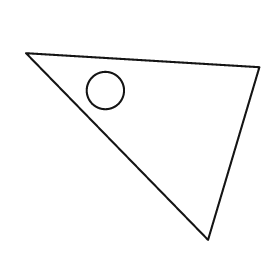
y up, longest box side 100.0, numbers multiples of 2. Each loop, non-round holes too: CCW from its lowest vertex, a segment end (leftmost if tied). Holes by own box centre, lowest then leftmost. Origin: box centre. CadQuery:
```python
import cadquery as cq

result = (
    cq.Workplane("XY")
    .moveTo(28.0, -40.0)
    .lineTo(50.0, 34.0)
    .lineTo(-50.0, 40.0)
    .close()
    .moveTo(-16.0, 24.0)
    .circle(8.0)
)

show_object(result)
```